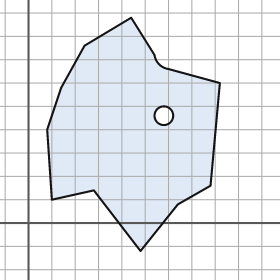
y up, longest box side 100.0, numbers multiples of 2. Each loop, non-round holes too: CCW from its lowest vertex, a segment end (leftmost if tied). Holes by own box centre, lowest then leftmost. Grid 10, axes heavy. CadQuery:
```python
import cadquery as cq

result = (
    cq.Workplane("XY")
    .moveTo(48.0, -12.0)
    .lineTo(64.0, 8.0)
    .lineTo(78.0, 16.0)
    .lineTo(82.0, 60.0)
    .lineTo(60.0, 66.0)
    .threePointArc((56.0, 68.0), (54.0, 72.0))
    .lineTo(44.0, 88.0)
    .lineTo(24.0, 76.0)
    .lineTo(14.0, 58.0)
    .lineTo(8.0, 40.0)
    .lineTo(10.0, 10.0)
    .lineTo(28.0, 14.0)
    .close()
    .moveTo(58.0, 46.0)
    .circle(4.0)
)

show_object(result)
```